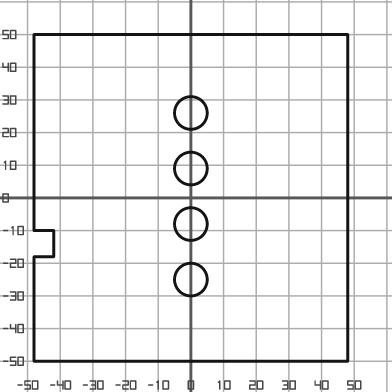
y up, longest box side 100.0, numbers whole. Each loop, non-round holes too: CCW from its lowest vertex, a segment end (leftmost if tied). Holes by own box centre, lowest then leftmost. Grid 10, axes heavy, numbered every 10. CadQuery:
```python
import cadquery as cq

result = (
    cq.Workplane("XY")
    .moveTo(-48.0, -50.0)
    .lineTo(48.0, -50.0)
    .lineTo(48.0, 50.0)
    .lineTo(-48.0, 50.0)
    .lineTo(-48.0, -10.0)
    .lineTo(-42.0, -10.0)
    .lineTo(-42.0, -18.0)
    .lineTo(-48.0, -18.0)
    .close()
    .moveTo(0.0, -25.0)
    .circle(5.0)
    .moveTo(0.0, -8.0)
    .circle(5.0)
    .moveTo(0.0, 9.0)
    .circle(5.0)
    .moveTo(0.0, 26.0)
    .circle(5.0)
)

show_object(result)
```